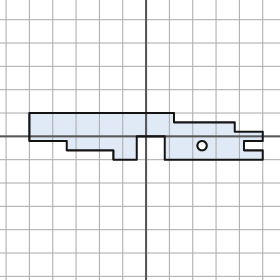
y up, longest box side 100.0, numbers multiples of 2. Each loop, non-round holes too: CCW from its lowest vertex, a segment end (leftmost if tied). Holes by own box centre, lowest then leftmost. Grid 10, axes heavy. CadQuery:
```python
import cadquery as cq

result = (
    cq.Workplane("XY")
    .moveTo(-14.0, -10.0)
    .lineTo(-4.0, -10.0)
    .lineTo(-4.0, 0.0)
    .lineTo(8.0, 0.0)
    .lineTo(8.0, -10.0)
    .lineTo(50.0, -10.0)
    .lineTo(50.0, -6.0)
    .lineTo(42.0, -6.0)
    .lineTo(42.0, -2.0)
    .lineTo(50.0, -2.0)
    .lineTo(50.0, 2.0)
    .lineTo(38.0, 2.0)
    .lineTo(38.0, 6.0)
    .lineTo(12.0, 6.0)
    .lineTo(12.0, 10.0)
    .lineTo(-50.0, 10.0)
    .lineTo(-50.0, -2.0)
    .lineTo(-34.0, -2.0)
    .lineTo(-34.0, -6.0)
    .lineTo(-14.0, -6.0)
    .close()
    .moveTo(24.0, -4.0)
    .circle(2.0)
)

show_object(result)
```